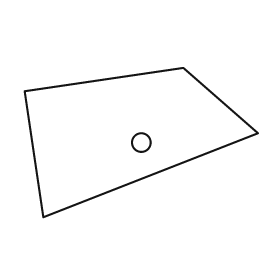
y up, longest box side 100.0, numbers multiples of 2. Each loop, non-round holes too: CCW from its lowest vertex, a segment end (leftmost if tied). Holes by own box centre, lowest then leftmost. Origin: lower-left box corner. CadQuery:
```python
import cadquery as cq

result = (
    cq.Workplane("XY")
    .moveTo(8.0, 0.0)
    .lineTo(100.0, 36.0)
    .lineTo(68.0, 64.0)
    .lineTo(0.0, 54.0)
    .close()
    .moveTo(50.0, 32.0)
    .circle(4.0)
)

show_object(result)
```